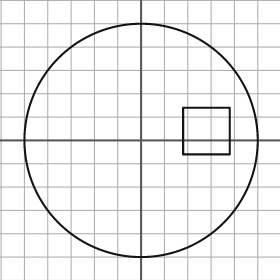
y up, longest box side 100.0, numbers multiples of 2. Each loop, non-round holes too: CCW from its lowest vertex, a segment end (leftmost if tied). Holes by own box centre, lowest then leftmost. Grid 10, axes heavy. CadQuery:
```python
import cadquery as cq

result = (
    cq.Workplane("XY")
    .moveTo(0.0, 0.0)
    .circle(50.0)
    .moveTo(18.0, -6.0)
    .lineTo(38.0, -6.0)
    .lineTo(38.0, 14.0)
    .lineTo(18.0, 14.0)
    .close()
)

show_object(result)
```